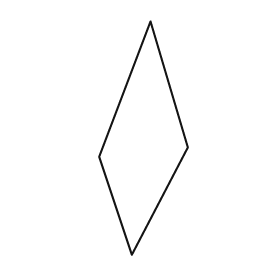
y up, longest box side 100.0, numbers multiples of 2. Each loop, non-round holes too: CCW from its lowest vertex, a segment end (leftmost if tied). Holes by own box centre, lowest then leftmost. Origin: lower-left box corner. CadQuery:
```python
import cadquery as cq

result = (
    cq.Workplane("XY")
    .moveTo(14.0, 0.0)
    .lineTo(38.0, 46.0)
    .lineTo(22.0, 100.0)
    .lineTo(0.0, 42.0)
    .close()
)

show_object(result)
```